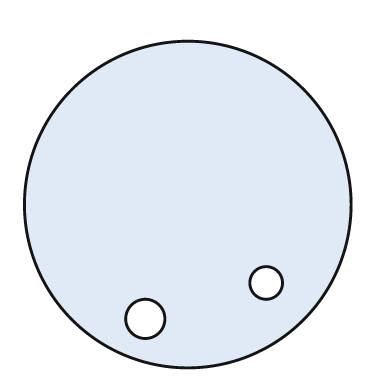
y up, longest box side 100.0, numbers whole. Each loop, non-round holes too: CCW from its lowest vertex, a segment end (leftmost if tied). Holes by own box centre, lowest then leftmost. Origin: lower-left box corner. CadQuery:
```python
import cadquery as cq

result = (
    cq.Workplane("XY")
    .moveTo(50.0, 50.0)
    .circle(50.0)
    .moveTo(37.0, 15.0)
    .circle(6.0)
    .moveTo(74.0, 26.0)
    .circle(5.0)
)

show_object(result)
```